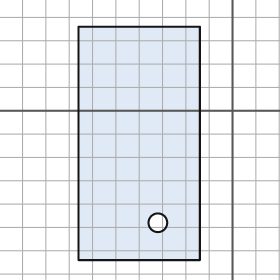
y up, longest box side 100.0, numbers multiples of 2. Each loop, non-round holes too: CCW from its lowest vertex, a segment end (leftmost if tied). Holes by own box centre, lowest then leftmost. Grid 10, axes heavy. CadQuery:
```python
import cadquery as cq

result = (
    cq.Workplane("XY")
    .moveTo(-66.0, -64.0)
    .lineTo(-14.0, -64.0)
    .lineTo(-14.0, 36.0)
    .lineTo(-66.0, 36.0)
    .close()
    .moveTo(-32.0, -48.0)
    .circle(4.0)
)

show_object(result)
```